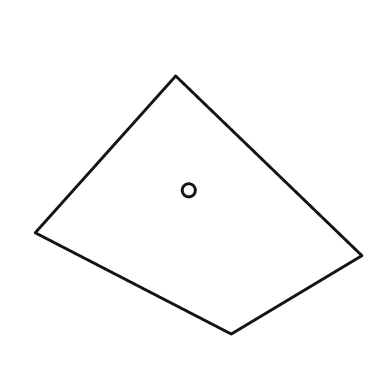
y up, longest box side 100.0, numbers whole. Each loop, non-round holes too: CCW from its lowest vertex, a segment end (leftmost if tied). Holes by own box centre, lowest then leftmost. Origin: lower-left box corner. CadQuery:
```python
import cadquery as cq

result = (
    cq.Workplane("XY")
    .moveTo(60.0, 0.0)
    .lineTo(100.0, 24.0)
    .lineTo(43.0, 79.0)
    .lineTo(0.0, 31.0)
    .close()
    .moveTo(47.0, 44.0)
    .circle(2.0)
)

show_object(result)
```